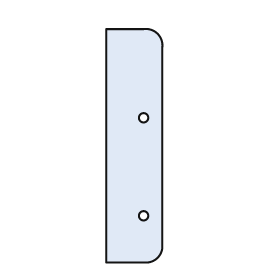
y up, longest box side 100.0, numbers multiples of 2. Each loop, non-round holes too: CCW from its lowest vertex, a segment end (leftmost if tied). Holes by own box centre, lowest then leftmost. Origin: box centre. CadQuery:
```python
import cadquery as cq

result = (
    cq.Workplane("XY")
    .moveTo(-12.0, -50.0)
    .lineTo(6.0, -50.0)
    .threePointArc((10.0, -48.0), (12.0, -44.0))
    .lineTo(12.0, 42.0)
    .threePointArc((10.0, 48.0), (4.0, 50.0))
    .lineTo(-12.0, 50.0)
    .close()
    .moveTo(4.0, -30.0)
    .circle(2.0)
    .moveTo(4.0, 12.0)
    .circle(2.0)
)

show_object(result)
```